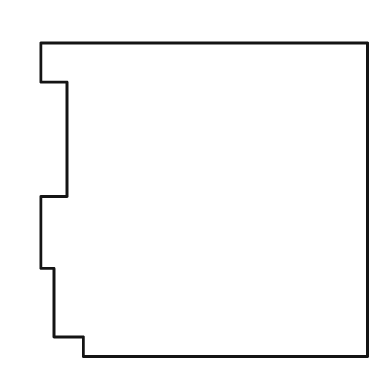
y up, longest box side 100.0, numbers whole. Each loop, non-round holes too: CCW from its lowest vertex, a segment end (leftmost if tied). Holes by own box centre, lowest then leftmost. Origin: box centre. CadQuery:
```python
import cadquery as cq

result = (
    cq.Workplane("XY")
    .moveTo(-37.0, -48.0)
    .lineTo(50.0, -48.0)
    .lineTo(50.0, 48.0)
    .lineTo(-50.0, 48.0)
    .lineTo(-50.0, 36.0)
    .lineTo(-42.0, 36.0)
    .lineTo(-42.0, 1.0)
    .lineTo(-50.0, 1.0)
    .lineTo(-50.0, -21.0)
    .lineTo(-46.0, -21.0)
    .lineTo(-46.0, -42.0)
    .lineTo(-37.0, -42.0)
    .close()
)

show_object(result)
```